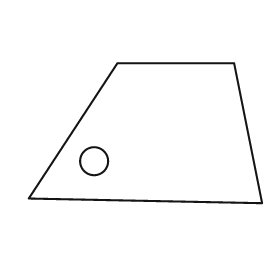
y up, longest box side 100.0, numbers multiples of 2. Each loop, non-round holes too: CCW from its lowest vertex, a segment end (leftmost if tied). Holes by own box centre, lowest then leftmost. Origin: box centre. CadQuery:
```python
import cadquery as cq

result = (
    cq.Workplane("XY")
    .moveTo(50.0, -30.0)
    .lineTo(38.0, 30.0)
    .lineTo(-12.0, 30.0)
    .lineTo(-50.0, -28.0)
    .close()
    .moveTo(-22.0, -12.0)
    .circle(6.0)
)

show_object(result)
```